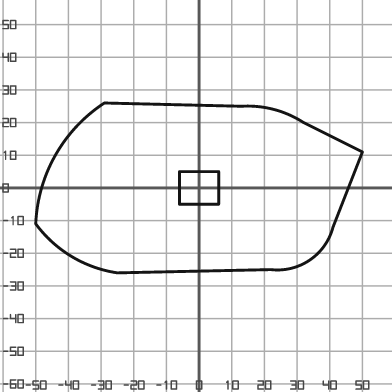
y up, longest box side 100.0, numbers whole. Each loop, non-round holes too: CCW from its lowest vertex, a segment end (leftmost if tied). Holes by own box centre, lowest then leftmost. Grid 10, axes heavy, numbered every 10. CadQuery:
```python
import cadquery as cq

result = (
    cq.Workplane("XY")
    .moveTo(-25.0, -26.0)
    .lineTo(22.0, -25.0)
    .threePointArc((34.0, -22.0), (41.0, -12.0))
    .lineTo(50.0, 11.0)
    .lineTo(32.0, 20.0)
    .threePointArc((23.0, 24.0), (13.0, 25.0))
    .lineTo(-29.0, 26.0)
    .threePointArc((-44.0, 10.0), (-50.0, -11.0))
    .threePointArc((-39.0, -21.0), (-25.0, -26.0))
    .close()
    .moveTo(-6.0, -5.0)
    .lineTo(6.0, -5.0)
    .lineTo(6.0, 5.0)
    .lineTo(-6.0, 5.0)
    .close()
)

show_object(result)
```